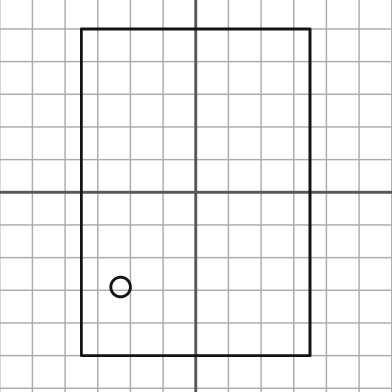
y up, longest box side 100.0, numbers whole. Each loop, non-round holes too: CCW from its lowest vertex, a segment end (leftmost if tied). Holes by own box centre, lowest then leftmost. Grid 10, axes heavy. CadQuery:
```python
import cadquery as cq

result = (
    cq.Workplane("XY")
    .moveTo(-35.0, -50.0)
    .lineTo(35.0, -50.0)
    .lineTo(35.0, 50.0)
    .lineTo(-35.0, 50.0)
    .close()
    .moveTo(-23.0, -29.0)
    .circle(3.0)
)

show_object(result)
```